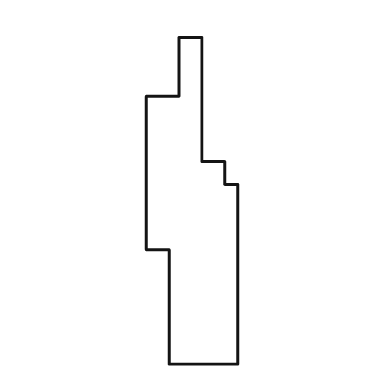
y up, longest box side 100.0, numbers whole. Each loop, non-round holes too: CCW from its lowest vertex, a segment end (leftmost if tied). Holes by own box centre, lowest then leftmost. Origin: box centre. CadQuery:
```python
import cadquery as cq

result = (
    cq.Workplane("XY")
    .moveTo(-7.0, -50.0)
    .lineTo(14.0, -50.0)
    .lineTo(14.0, 5.0)
    .lineTo(10.0, 5.0)
    .lineTo(10.0, 12.0)
    .lineTo(3.0, 12.0)
    .lineTo(3.0, 50.0)
    .lineTo(-4.0, 50.0)
    .lineTo(-4.0, 32.0)
    .lineTo(-14.0, 32.0)
    .lineTo(-14.0, -15.0)
    .lineTo(-7.0, -15.0)
    .close()
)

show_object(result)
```